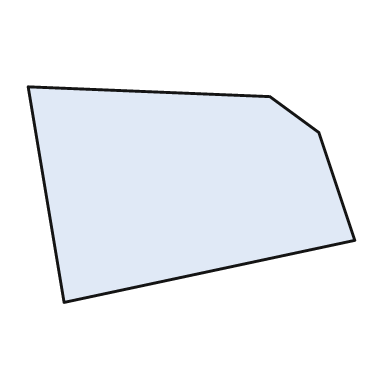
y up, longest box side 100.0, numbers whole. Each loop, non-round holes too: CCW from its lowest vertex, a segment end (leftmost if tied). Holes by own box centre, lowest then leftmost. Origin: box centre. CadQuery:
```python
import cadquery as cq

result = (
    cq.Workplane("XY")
    .moveTo(-39.0, -33.0)
    .lineTo(50.0, -14.0)
    .lineTo(39.0, 19.0)
    .lineTo(24.0, 30.0)
    .lineTo(-50.0, 33.0)
    .close()
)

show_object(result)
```